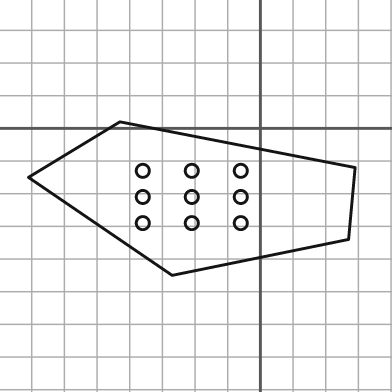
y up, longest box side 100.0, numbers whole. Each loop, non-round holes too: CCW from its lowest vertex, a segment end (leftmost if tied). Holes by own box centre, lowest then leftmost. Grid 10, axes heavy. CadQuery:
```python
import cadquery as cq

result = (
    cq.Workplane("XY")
    .moveTo(-27.0, -45.0)
    .lineTo(27.0, -34.0)
    .lineTo(29.0, -12.0)
    .lineTo(-43.0, 2.0)
    .lineTo(-71.0, -15.0)
    .close()
    .moveTo(-36.0, -29.0)
    .circle(2.0)
    .moveTo(-21.0, -29.0)
    .circle(2.0)
    .moveTo(-6.0, -29.0)
    .circle(2.0)
    .moveTo(-36.0, -21.0)
    .circle(2.0)
    .moveTo(-21.0, -21.0)
    .circle(2.0)
    .moveTo(-6.0, -21.0)
    .circle(2.0)
    .moveTo(-36.0, -13.0)
    .circle(2.0)
    .moveTo(-21.0, -13.0)
    .circle(2.0)
    .moveTo(-6.0, -13.0)
    .circle(2.0)
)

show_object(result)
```